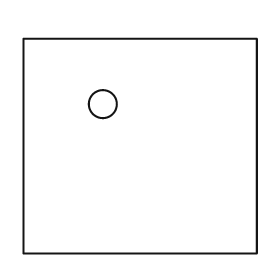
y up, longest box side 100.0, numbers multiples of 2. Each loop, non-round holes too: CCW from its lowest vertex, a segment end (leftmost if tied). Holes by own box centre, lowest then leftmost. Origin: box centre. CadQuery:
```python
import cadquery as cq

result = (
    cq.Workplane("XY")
    .moveTo(-50.0, -46.0)
    .lineTo(50.0, -46.0)
    .lineTo(50.0, 46.0)
    .lineTo(-50.0, 46.0)
    .close()
    .moveTo(-16.0, 18.0)
    .circle(6.0)
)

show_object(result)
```